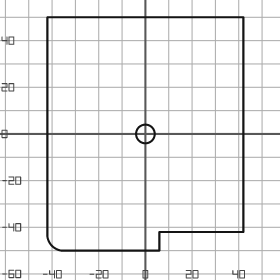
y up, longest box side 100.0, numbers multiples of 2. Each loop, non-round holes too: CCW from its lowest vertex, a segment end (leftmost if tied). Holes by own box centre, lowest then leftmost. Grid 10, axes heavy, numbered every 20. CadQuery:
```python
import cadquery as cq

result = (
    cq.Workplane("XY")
    .moveTo(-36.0, -50.0)
    .lineTo(6.0, -50.0)
    .lineTo(6.0, -42.0)
    .lineTo(42.0, -42.0)
    .lineTo(42.0, 50.0)
    .lineTo(-42.0, 50.0)
    .lineTo(-42.0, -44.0)
    .threePointArc((-40.0, -48.0), (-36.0, -50.0))
    .close()
    .moveTo(0.0, 0.0)
    .circle(4.0)
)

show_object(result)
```